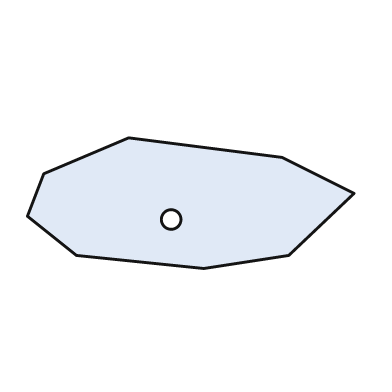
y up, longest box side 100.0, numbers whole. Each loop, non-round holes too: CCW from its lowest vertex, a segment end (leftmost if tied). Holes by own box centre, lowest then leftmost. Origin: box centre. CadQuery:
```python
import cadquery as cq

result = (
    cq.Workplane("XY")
    .moveTo(4.0, -20.0)
    .lineTo(30.0, -16.0)
    .lineTo(50.0, 3.0)
    .lineTo(28.0, 14.0)
    .lineTo(-19.0, 20.0)
    .lineTo(-45.0, 9.0)
    .lineTo(-50.0, -4.0)
    .lineTo(-35.0, -16.0)
    .close()
    .moveTo(-6.0, -5.0)
    .circle(3.0)
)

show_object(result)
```